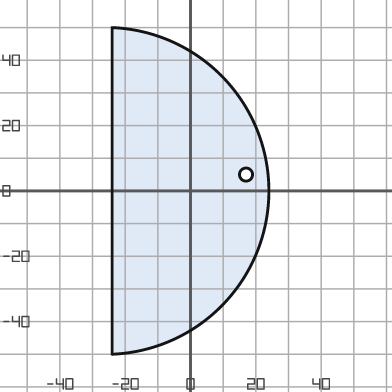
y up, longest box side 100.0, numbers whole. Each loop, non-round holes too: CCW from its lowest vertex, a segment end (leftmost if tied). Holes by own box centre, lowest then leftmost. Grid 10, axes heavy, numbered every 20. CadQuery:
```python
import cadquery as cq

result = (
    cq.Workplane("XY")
    .moveTo(-24.0, -50.0)
    .threePointArc((24.0, 0.0), (-24.0, 50.0))
    .close()
    .moveTo(17.0, 5.0)
    .circle(2.0)
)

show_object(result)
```